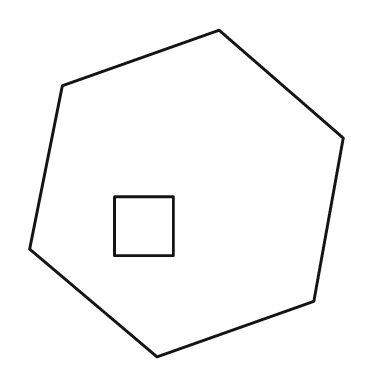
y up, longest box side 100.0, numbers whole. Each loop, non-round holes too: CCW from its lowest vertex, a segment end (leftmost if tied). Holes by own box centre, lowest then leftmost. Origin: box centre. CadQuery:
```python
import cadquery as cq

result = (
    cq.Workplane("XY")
    .moveTo(-9.0, -50.0)
    .lineTo(39.0, -33.0)
    .lineTo(48.0, 17.0)
    .lineTo(10.0, 50.0)
    .lineTo(-38.0, 33.0)
    .lineTo(-48.0, -17.0)
    .close()
    .moveTo(-22.0, -19.0)
    .lineTo(-4.0, -19.0)
    .lineTo(-4.0, -1.0)
    .lineTo(-22.0, -1.0)
    .close()
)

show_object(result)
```